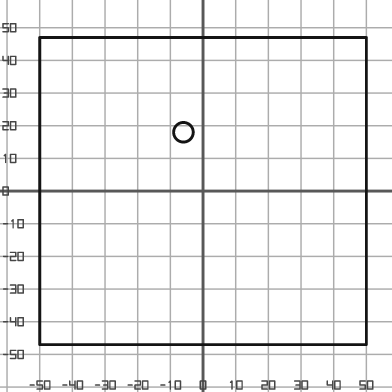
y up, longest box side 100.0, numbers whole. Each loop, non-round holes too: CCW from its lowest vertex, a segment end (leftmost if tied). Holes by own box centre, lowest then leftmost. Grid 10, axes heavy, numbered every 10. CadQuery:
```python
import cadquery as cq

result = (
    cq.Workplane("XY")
    .moveTo(-50.0, -47.0)
    .lineTo(50.0, -47.0)
    .lineTo(50.0, 47.0)
    .lineTo(-50.0, 47.0)
    .close()
    .moveTo(-6.0, 18.0)
    .circle(3.0)
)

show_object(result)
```